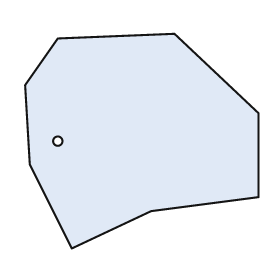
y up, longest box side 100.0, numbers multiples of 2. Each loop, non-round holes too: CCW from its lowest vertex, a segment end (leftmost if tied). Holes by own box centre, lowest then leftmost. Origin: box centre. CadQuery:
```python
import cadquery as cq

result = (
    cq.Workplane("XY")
    .moveTo(-30.0, -46.0)
    .lineTo(4.0, -30.0)
    .lineTo(50.0, -24.0)
    .lineTo(50.0, 12.0)
    .lineTo(14.0, 46.0)
    .lineTo(-36.0, 44.0)
    .lineTo(-50.0, 24.0)
    .lineTo(-48.0, -10.0)
    .close()
    .moveTo(-36.0, 0.0)
    .circle(2.0)
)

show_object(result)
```